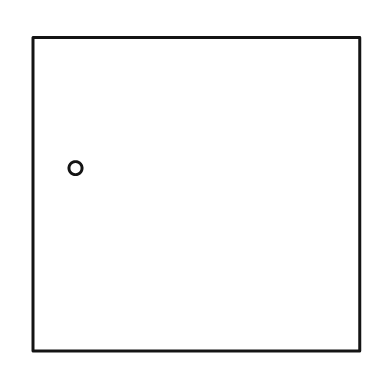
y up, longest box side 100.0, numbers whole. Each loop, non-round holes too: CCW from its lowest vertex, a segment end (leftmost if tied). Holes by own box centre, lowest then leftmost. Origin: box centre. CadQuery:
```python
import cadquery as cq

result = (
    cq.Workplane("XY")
    .moveTo(-50.0, -48.0)
    .lineTo(50.0, -48.0)
    .lineTo(50.0, 48.0)
    .lineTo(-50.0, 48.0)
    .close()
    .moveTo(-37.0, 8.0)
    .circle(2.0)
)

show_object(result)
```